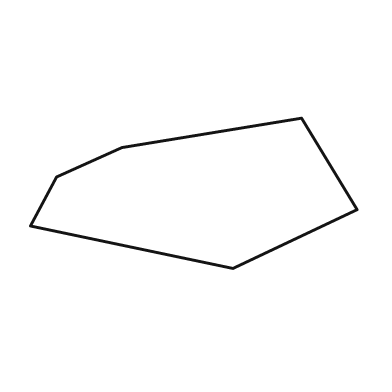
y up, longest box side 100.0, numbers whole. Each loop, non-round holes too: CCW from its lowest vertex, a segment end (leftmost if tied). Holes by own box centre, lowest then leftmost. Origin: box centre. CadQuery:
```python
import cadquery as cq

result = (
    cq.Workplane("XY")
    .moveTo(12.0, -23.0)
    .lineTo(50.0, -5.0)
    .lineTo(33.0, 23.0)
    .lineTo(-22.0, 14.0)
    .lineTo(-42.0, 5.0)
    .lineTo(-50.0, -10.0)
    .close()
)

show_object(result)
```